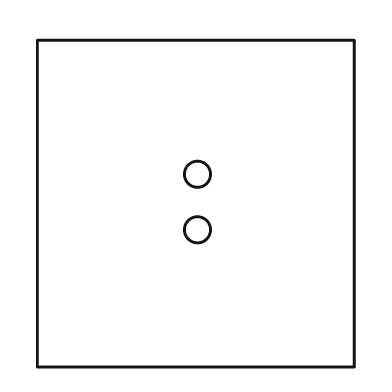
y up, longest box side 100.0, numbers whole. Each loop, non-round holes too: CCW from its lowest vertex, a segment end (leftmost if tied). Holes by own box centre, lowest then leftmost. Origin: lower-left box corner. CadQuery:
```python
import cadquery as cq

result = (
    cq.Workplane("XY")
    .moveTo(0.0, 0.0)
    .lineTo(97.0, 0.0)
    .lineTo(97.0, 100.0)
    .lineTo(0.0, 100.0)
    .close()
    .moveTo(49.0, 42.0)
    .circle(4.0)
    .moveTo(49.0, 59.0)
    .circle(4.0)
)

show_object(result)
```